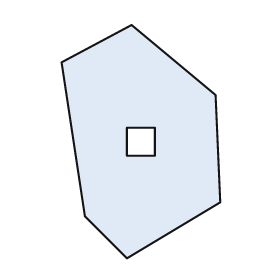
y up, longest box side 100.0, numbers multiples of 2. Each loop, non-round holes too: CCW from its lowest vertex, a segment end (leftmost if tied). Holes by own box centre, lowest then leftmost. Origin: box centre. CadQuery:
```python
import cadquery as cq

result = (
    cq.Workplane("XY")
    .moveTo(-6.0, -50.0)
    .lineTo(34.0, -26.0)
    .lineTo(32.0, 20.0)
    .lineTo(-4.0, 50.0)
    .lineTo(-34.0, 34.0)
    .lineTo(-24.0, -32.0)
    .close()
    .moveTo(-6.0, -6.0)
    .lineTo(6.0, -6.0)
    .lineTo(6.0, 6.0)
    .lineTo(-6.0, 6.0)
    .close()
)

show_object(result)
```